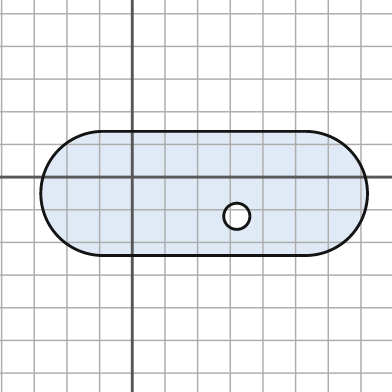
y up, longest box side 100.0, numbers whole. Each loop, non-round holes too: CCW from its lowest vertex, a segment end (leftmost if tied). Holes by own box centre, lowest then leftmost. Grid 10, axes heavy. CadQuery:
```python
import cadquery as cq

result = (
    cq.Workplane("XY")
    .moveTo(-9.0, -24.0)
    .lineTo(53.0, -24.0)
    .threePointArc((72.0, -5.0), (53.0, 14.0))
    .lineTo(-9.0, 14.0)
    .threePointArc((-28.0, -5.0), (-9.0, -24.0))
    .close()
    .moveTo(32.0, -12.0)
    .circle(4.0)
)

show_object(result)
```